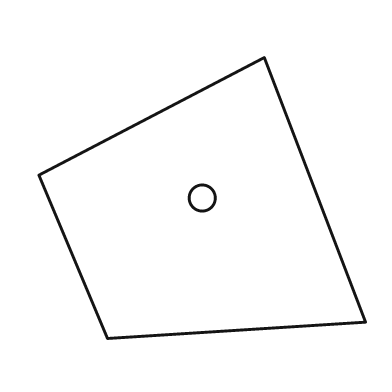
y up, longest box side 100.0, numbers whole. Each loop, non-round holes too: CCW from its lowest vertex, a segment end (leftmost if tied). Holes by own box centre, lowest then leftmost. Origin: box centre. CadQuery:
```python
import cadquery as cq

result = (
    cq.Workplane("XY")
    .moveTo(-29.0, -43.0)
    .lineTo(50.0, -38.0)
    .lineTo(19.0, 43.0)
    .lineTo(-50.0, 7.0)
    .close()
    .moveTo(0.0, 0.0)
    .circle(4.0)
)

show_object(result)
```